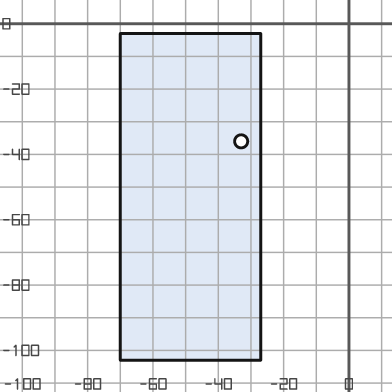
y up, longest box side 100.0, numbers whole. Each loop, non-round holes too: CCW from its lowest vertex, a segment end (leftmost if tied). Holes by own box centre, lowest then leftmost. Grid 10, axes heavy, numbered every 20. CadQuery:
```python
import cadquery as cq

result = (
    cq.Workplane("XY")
    .moveTo(-70.0, -103.0)
    .lineTo(-27.0, -103.0)
    .lineTo(-27.0, -3.0)
    .lineTo(-70.0, -3.0)
    .close()
    .moveTo(-33.0, -36.0)
    .circle(2.0)
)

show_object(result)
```